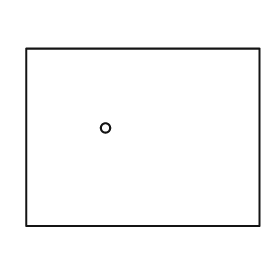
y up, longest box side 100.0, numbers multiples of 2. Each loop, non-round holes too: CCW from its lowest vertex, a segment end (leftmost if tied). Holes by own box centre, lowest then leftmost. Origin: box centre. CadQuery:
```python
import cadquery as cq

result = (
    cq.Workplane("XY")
    .moveTo(-50.0, -38.0)
    .lineTo(50.0, -38.0)
    .lineTo(50.0, 38.0)
    .lineTo(-50.0, 38.0)
    .close()
    .moveTo(-16.0, 4.0)
    .circle(2.0)
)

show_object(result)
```